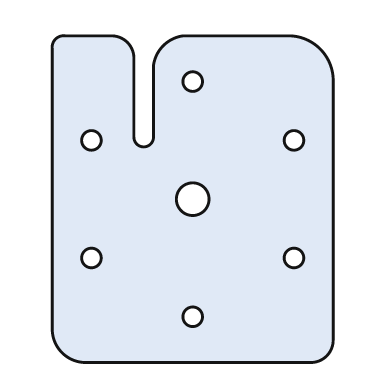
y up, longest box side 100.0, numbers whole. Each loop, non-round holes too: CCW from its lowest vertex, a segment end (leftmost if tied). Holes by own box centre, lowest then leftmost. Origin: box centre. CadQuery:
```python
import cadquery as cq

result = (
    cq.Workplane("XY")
    .moveTo(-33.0, -50.0)
    .lineTo(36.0, -50.0)
    .threePointArc((41.0, -48.0), (43.0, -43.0))
    .lineTo(43.0, 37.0)
    .threePointArc((39.0, 46.0), (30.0, 50.0))
    .lineTo(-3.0, 50.0)
    .threePointArc((-9.0, 47.0), (-12.0, 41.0))
    .lineTo(-12.0, 19.0)
    .threePointArc((-15.0, 16.0), (-18.0, 19.0))
    .lineTo(-18.0, 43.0)
    .threePointArc((-20.0, 48.0), (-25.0, 50.0))
    .lineTo(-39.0, 50.0)
    .threePointArc((-42.0, 49.0), (-43.0, 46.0))
    .lineTo(-43.0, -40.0)
    .threePointArc((-40.0, -47.0), (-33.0, -50.0))
    .close()
    .moveTo(0.0, -36.0)
    .circle(3.0)
    .moveTo(-31.0, -18.0)
    .circle(3.0)
    .moveTo(31.0, -18.0)
    .circle(3.0)
    .moveTo(0.0, 0.0)
    .circle(5.0)
    .moveTo(-31.0, 18.0)
    .circle(3.0)
    .moveTo(31.0, 18.0)
    .circle(3.0)
    .moveTo(0.0, 36.0)
    .circle(3.0)
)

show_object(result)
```